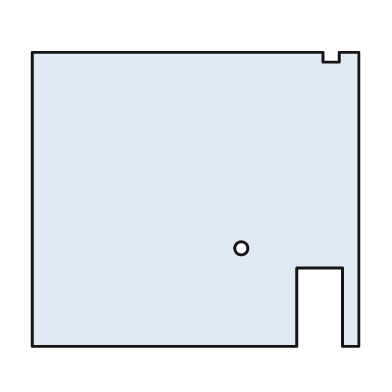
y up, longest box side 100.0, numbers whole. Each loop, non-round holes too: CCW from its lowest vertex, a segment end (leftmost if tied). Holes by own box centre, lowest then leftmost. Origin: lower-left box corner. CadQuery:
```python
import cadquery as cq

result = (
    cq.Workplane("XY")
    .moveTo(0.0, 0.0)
    .lineTo(81.0, 0.0)
    .lineTo(81.0, 24.0)
    .lineTo(95.0, 24.0)
    .lineTo(95.0, 0.0)
    .lineTo(100.0, 0.0)
    .lineTo(100.0, 90.0)
    .lineTo(94.0, 90.0)
    .lineTo(94.0, 87.0)
    .lineTo(89.0, 87.0)
    .lineTo(89.0, 90.0)
    .lineTo(0.0, 90.0)
    .close()
    .moveTo(64.0, 30.0)
    .circle(2.0)
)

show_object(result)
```